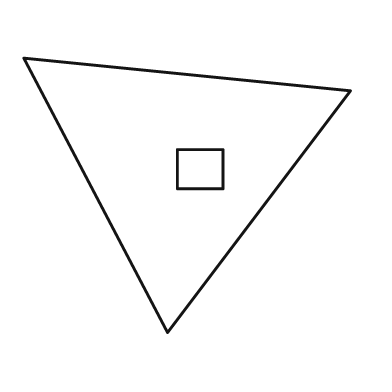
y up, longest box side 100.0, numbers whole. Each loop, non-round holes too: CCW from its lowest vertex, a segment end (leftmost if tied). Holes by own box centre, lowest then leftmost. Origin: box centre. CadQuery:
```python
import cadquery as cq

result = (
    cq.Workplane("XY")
    .moveTo(-6.0, -42.0)
    .lineTo(50.0, 32.0)
    .lineTo(-50.0, 42.0)
    .close()
    .moveTo(-3.0, 2.0)
    .lineTo(11.0, 2.0)
    .lineTo(11.0, 14.0)
    .lineTo(-3.0, 14.0)
    .close()
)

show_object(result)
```